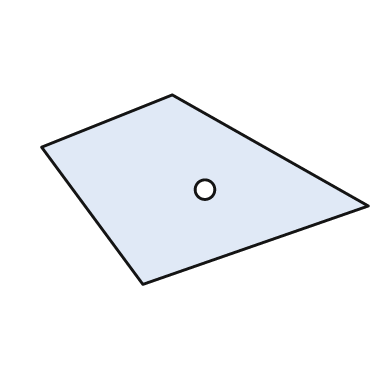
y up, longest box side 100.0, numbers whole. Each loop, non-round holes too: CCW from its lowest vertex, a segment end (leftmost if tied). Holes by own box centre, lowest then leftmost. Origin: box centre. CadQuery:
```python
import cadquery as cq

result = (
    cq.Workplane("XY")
    .moveTo(-19.0, -29.0)
    .lineTo(50.0, -5.0)
    .lineTo(-10.0, 29.0)
    .lineTo(-50.0, 13.0)
    .close()
    .moveTo(0.0, 0.0)
    .circle(3.0)
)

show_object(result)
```